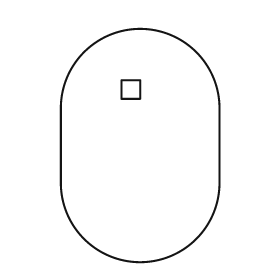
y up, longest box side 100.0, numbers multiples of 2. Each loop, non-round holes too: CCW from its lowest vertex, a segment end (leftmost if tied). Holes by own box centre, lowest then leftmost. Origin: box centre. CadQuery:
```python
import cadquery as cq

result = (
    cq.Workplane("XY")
    .moveTo(-34.0, -16.0)
    .threePointArc((0.0, -50.0), (34.0, -16.0))
    .lineTo(34.0, 16.0)
    .threePointArc((0.0, 50.0), (-34.0, 16.0))
    .close()
    .moveTo(-8.0, 20.0)
    .lineTo(0.0, 20.0)
    .lineTo(0.0, 28.0)
    .lineTo(-8.0, 28.0)
    .close()
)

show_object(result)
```